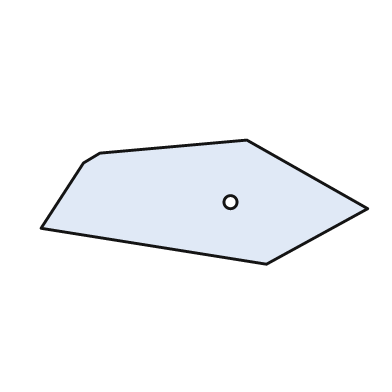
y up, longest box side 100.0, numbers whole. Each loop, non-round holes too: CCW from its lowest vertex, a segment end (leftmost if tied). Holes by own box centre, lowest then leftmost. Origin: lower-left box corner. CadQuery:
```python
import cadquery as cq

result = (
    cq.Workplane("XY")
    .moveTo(69.0, 0.0)
    .lineTo(100.0, 17.0)
    .lineTo(63.0, 38.0)
    .lineTo(18.0, 34.0)
    .lineTo(13.0, 31.0)
    .lineTo(0.0, 11.0)
    .close()
    .moveTo(58.0, 19.0)
    .circle(2.0)
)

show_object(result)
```